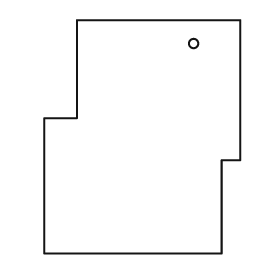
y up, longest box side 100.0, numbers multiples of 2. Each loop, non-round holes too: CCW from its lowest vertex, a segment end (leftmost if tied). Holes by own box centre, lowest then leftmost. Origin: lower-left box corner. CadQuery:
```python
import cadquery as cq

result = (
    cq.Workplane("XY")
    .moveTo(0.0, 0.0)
    .lineTo(76.0, 0.0)
    .lineTo(76.0, 40.0)
    .lineTo(84.0, 40.0)
    .lineTo(84.0, 100.0)
    .lineTo(14.0, 100.0)
    .lineTo(14.0, 58.0)
    .lineTo(0.0, 58.0)
    .close()
    .moveTo(64.0, 90.0)
    .circle(2.0)
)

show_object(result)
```